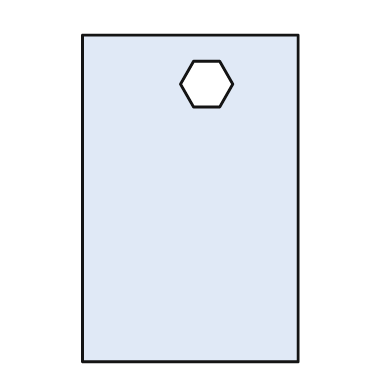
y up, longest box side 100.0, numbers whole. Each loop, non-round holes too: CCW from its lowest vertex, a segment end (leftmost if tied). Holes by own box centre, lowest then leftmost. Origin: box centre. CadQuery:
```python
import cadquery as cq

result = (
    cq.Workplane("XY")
    .moveTo(-33.0, -50.0)
    .lineTo(33.0, -50.0)
    .lineTo(33.0, 50.0)
    .lineTo(-33.0, 50.0)
    .close()
    .moveTo(1.0, 28.0)
    .lineTo(9.0, 28.0)
    .lineTo(13.0, 35.0)
    .lineTo(9.0, 42.0)
    .lineTo(1.0, 42.0)
    .lineTo(-3.0, 35.0)
    .close()
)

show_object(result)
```